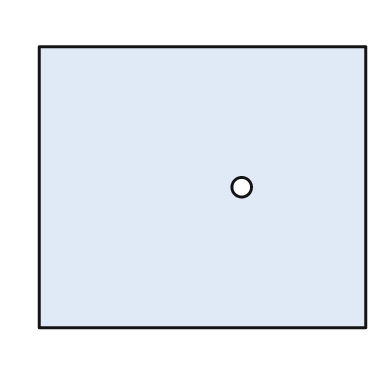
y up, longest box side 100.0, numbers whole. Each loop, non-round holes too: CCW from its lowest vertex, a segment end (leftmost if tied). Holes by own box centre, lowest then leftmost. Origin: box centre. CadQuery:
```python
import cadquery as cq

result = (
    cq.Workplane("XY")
    .moveTo(-50.0, -43.0)
    .lineTo(50.0, -43.0)
    .lineTo(50.0, 43.0)
    .lineTo(-50.0, 43.0)
    .close()
    .moveTo(12.0, 0.0)
    .circle(3.0)
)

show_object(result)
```